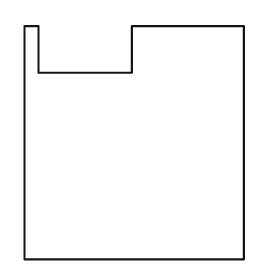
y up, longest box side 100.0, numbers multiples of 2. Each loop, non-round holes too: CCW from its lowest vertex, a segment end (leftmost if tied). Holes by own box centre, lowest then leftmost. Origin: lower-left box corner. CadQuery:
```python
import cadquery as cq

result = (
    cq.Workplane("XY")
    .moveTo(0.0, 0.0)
    .lineTo(94.0, 0.0)
    .lineTo(94.0, 100.0)
    .lineTo(46.0, 100.0)
    .lineTo(46.0, 80.0)
    .lineTo(6.0, 80.0)
    .lineTo(6.0, 100.0)
    .lineTo(0.0, 100.0)
    .close()
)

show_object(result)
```